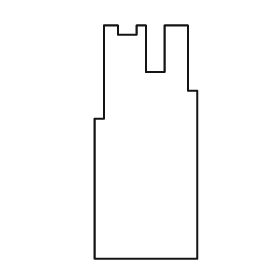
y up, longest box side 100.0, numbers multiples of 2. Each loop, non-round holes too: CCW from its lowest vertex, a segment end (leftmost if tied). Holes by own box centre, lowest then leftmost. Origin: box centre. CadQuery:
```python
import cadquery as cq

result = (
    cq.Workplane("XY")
    .moveTo(-22.0, -50.0)
    .lineTo(22.0, -50.0)
    .lineTo(22.0, 22.0)
    .lineTo(18.0, 22.0)
    .lineTo(18.0, 50.0)
    .lineTo(8.0, 50.0)
    .lineTo(8.0, 30.0)
    .lineTo(0.0, 30.0)
    .lineTo(0.0, 50.0)
    .lineTo(-4.0, 50.0)
    .lineTo(-4.0, 46.0)
    .lineTo(-12.0, 46.0)
    .lineTo(-12.0, 50.0)
    .lineTo(-18.0, 50.0)
    .lineTo(-18.0, 10.0)
    .lineTo(-22.0, 10.0)
    .close()
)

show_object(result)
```